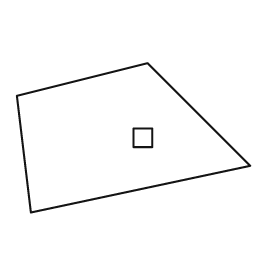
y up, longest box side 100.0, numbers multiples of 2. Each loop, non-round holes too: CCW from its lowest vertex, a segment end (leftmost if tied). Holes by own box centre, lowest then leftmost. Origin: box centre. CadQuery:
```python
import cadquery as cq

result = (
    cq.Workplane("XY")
    .moveTo(-44.0, -32.0)
    .lineTo(50.0, -12.0)
    .lineTo(6.0, 32.0)
    .lineTo(-50.0, 18.0)
    .close()
    .moveTo(0.0, -4.0)
    .lineTo(8.0, -4.0)
    .lineTo(8.0, 4.0)
    .lineTo(0.0, 4.0)
    .close()
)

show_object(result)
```